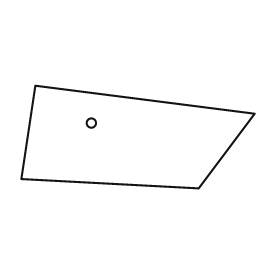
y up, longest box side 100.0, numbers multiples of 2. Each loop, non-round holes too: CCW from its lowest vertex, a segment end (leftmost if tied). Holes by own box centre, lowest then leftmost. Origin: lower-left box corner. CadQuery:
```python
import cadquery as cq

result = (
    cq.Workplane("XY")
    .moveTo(76.0, 0.0)
    .lineTo(100.0, 32.0)
    .lineTo(6.0, 44.0)
    .lineTo(0.0, 4.0)
    .close()
    .moveTo(30.0, 28.0)
    .circle(2.0)
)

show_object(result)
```